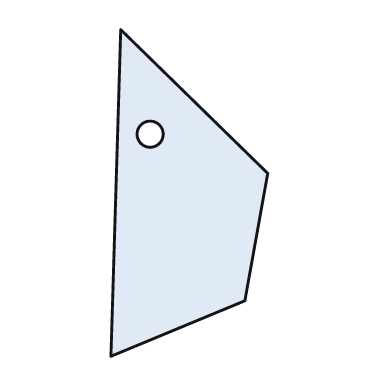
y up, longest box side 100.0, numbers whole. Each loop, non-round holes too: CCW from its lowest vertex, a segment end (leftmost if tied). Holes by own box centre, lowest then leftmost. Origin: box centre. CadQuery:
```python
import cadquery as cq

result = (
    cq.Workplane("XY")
    .moveTo(-24.0, -50.0)
    .lineTo(17.0, -33.0)
    .lineTo(24.0, 6.0)
    .lineTo(-21.0, 50.0)
    .close()
    .moveTo(-12.0, 18.0)
    .circle(4.0)
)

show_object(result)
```